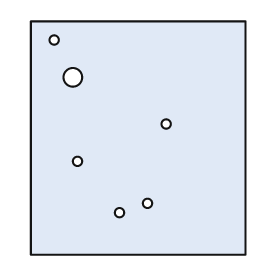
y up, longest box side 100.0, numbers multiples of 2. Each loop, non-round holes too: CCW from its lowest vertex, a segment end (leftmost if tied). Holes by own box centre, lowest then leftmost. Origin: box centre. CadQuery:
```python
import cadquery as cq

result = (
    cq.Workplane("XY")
    .moveTo(-46.0, -50.0)
    .lineTo(46.0, -50.0)
    .lineTo(46.0, 50.0)
    .lineTo(-46.0, 50.0)
    .close()
    .moveTo(-8.0, -32.0)
    .circle(2.0)
    .moveTo(4.0, -28.0)
    .circle(2.0)
    .moveTo(-26.0, -10.0)
    .circle(2.0)
    .moveTo(12.0, 6.0)
    .circle(2.0)
    .moveTo(-28.0, 26.0)
    .circle(4.0)
    .moveTo(-36.0, 42.0)
    .circle(2.0)
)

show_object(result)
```